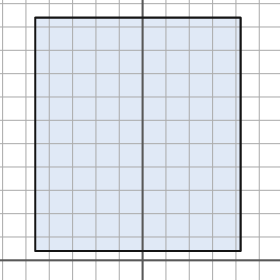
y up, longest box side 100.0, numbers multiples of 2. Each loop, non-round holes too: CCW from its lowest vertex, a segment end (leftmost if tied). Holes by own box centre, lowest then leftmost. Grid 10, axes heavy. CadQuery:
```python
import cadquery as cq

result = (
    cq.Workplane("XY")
    .moveTo(-46.0, 4.0)
    .lineTo(42.0, 4.0)
    .lineTo(42.0, 104.0)
    .lineTo(-46.0, 104.0)
    .close()
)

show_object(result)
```